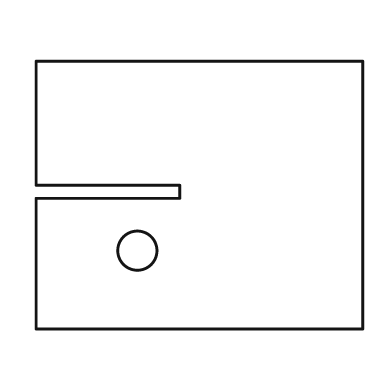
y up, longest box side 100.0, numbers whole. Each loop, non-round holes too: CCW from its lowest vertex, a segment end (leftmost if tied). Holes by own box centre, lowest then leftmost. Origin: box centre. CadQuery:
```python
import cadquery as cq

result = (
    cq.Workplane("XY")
    .moveTo(-50.0, -41.0)
    .lineTo(50.0, -41.0)
    .lineTo(50.0, 41.0)
    .lineTo(-50.0, 41.0)
    .lineTo(-50.0, 3.0)
    .lineTo(-6.0, 3.0)
    .lineTo(-6.0, -1.0)
    .lineTo(-50.0, -1.0)
    .close()
    .moveTo(-19.0, -17.0)
    .circle(6.0)
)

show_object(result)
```